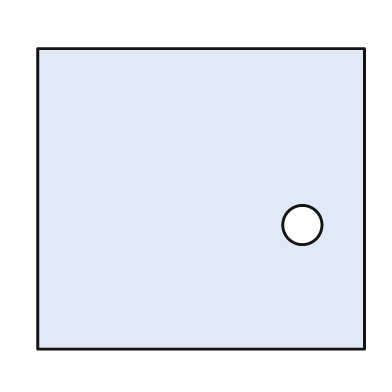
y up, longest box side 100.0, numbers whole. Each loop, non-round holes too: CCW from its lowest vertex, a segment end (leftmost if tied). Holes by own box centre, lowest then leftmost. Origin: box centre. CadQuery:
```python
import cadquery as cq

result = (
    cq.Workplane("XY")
    .moveTo(-50.0, -46.0)
    .lineTo(50.0, -46.0)
    .lineTo(50.0, 46.0)
    .lineTo(-50.0, 46.0)
    .close()
    .moveTo(31.0, -8.0)
    .circle(6.0)
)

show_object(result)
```